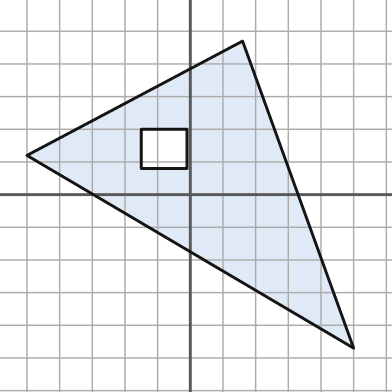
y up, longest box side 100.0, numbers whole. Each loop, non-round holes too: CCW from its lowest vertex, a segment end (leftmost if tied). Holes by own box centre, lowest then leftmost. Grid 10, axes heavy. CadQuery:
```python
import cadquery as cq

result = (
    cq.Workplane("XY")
    .moveTo(50.0, -47.0)
    .lineTo(16.0, 47.0)
    .lineTo(-50.0, 12.0)
    .close()
    .moveTo(-15.0, 8.0)
    .lineTo(-1.0, 8.0)
    .lineTo(-1.0, 20.0)
    .lineTo(-15.0, 20.0)
    .close()
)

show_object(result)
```